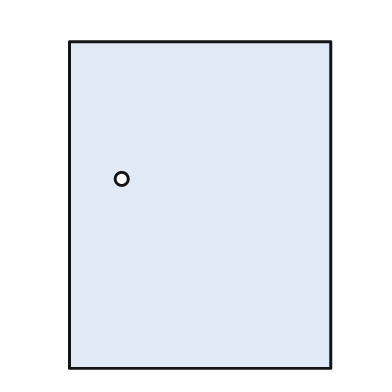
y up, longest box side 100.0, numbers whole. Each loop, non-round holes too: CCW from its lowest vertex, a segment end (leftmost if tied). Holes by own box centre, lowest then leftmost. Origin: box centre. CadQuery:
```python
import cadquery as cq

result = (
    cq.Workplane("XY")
    .moveTo(-40.0, -50.0)
    .lineTo(40.0, -50.0)
    .lineTo(40.0, 50.0)
    .lineTo(-40.0, 50.0)
    .close()
    .moveTo(-24.0, 8.0)
    .circle(2.0)
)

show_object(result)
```